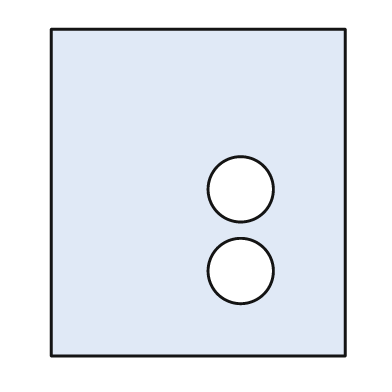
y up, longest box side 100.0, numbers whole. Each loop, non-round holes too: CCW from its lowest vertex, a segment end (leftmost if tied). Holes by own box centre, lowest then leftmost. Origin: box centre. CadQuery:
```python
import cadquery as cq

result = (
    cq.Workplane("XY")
    .moveTo(-45.0, -50.0)
    .lineTo(45.0, -50.0)
    .lineTo(45.0, 50.0)
    .lineTo(-45.0, 50.0)
    .close()
    .moveTo(13.0, -24.0)
    .circle(10.0)
    .moveTo(13.0, 1.0)
    .circle(10.0)
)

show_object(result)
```